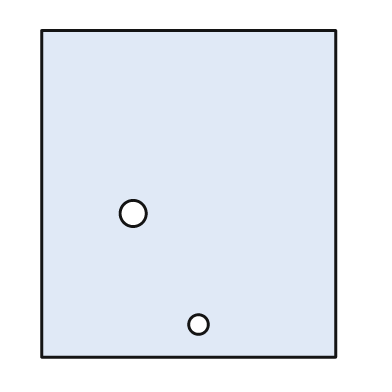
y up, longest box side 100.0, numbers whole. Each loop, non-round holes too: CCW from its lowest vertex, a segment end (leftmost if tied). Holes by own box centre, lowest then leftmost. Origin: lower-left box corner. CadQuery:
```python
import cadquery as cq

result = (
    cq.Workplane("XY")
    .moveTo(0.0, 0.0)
    .lineTo(90.0, 0.0)
    .lineTo(90.0, 100.0)
    .lineTo(0.0, 100.0)
    .close()
    .moveTo(48.0, 10.0)
    .circle(3.0)
    .moveTo(28.0, 44.0)
    .circle(4.0)
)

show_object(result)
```